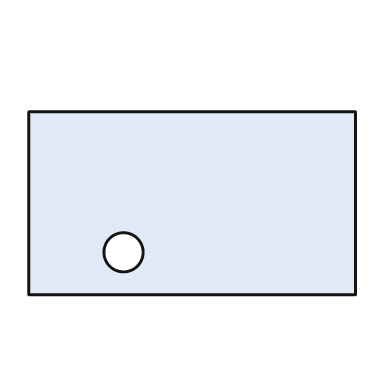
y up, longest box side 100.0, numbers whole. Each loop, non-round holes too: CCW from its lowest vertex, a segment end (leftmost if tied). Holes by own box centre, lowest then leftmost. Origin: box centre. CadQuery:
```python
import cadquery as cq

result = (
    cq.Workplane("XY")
    .moveTo(-50.0, -28.0)
    .lineTo(50.0, -28.0)
    .lineTo(50.0, 28.0)
    .lineTo(-50.0, 28.0)
    .close()
    .moveTo(-21.0, -15.0)
    .circle(6.0)
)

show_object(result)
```